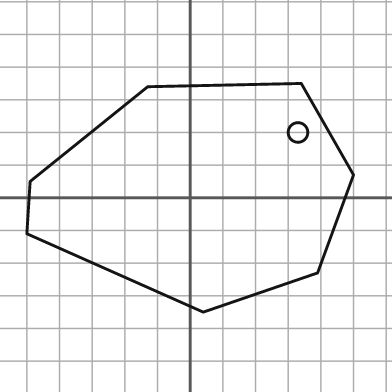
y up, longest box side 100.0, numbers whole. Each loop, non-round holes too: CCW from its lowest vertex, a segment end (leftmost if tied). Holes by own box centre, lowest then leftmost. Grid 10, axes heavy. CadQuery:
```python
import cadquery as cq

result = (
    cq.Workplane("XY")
    .moveTo(4.0, -35.0)
    .lineTo(39.0, -23.0)
    .lineTo(50.0, 7.0)
    .lineTo(34.0, 35.0)
    .lineTo(-13.0, 34.0)
    .lineTo(-49.0, 5.0)
    .lineTo(-50.0, -11.0)
    .close()
    .moveTo(33.0, 20.0)
    .circle(3.0)
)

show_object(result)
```